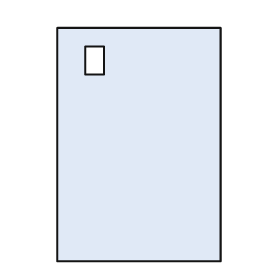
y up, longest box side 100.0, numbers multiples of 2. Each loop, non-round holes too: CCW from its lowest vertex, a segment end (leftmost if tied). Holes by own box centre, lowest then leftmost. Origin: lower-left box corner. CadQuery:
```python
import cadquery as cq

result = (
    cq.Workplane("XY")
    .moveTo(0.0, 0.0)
    .lineTo(70.0, 0.0)
    .lineTo(70.0, 100.0)
    .lineTo(0.0, 100.0)
    .close()
    .moveTo(12.0, 80.0)
    .lineTo(20.0, 80.0)
    .lineTo(20.0, 92.0)
    .lineTo(12.0, 92.0)
    .close()
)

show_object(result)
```